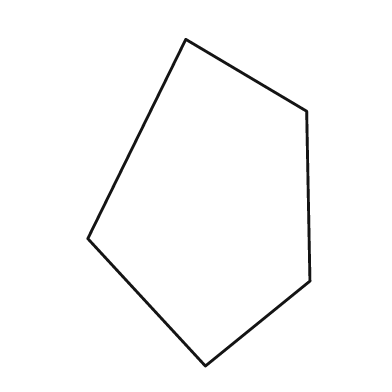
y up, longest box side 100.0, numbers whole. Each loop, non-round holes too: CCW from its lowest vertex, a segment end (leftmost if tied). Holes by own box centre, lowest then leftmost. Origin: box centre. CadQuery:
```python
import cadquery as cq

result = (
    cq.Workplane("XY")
    .moveTo(2.0, -50.0)
    .lineTo(34.0, -24.0)
    .lineTo(33.0, 28.0)
    .lineTo(-4.0, 50.0)
    .lineTo(-34.0, -11.0)
    .close()
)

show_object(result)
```